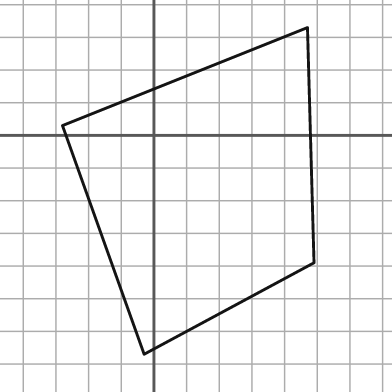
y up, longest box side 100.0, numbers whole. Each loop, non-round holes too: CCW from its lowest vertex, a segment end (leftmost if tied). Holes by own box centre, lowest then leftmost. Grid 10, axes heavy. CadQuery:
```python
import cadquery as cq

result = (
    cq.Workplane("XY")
    .moveTo(-3.0, -67.0)
    .lineTo(49.0, -39.0)
    .lineTo(47.0, 33.0)
    .lineTo(-28.0, 3.0)
    .close()
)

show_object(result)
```